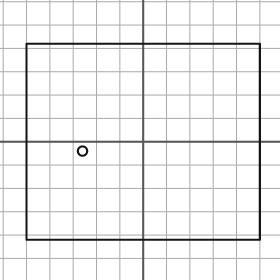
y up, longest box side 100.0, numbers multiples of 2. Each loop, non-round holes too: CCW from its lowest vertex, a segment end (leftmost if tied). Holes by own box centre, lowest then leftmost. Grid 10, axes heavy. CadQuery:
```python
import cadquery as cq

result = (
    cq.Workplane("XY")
    .moveTo(-50.0, -42.0)
    .lineTo(50.0, -42.0)
    .lineTo(50.0, 42.0)
    .lineTo(-50.0, 42.0)
    .close()
    .moveTo(-26.0, -4.0)
    .circle(2.0)
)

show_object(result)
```